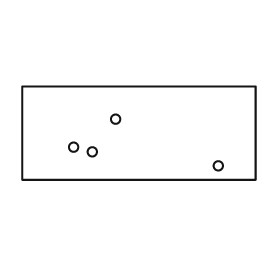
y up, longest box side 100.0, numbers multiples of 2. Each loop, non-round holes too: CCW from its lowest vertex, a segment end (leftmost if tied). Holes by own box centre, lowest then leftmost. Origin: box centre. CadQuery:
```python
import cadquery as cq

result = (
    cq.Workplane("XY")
    .moveTo(-50.0, -20.0)
    .lineTo(50.0, -20.0)
    .lineTo(50.0, 20.0)
    .lineTo(-50.0, 20.0)
    .close()
    .moveTo(34.0, -14.0)
    .circle(2.0)
    .moveTo(-20.0, -8.0)
    .circle(2.0)
    .moveTo(-28.0, -6.0)
    .circle(2.0)
    .moveTo(-10.0, 6.0)
    .circle(2.0)
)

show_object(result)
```